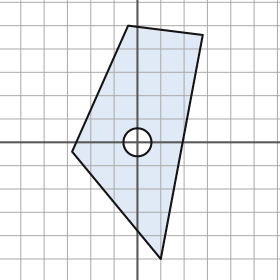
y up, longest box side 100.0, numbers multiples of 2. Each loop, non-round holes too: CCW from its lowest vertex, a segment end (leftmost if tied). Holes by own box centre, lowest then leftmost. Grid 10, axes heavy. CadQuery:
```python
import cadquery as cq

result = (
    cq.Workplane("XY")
    .moveTo(10.0, -50.0)
    .lineTo(28.0, 46.0)
    .lineTo(-4.0, 50.0)
    .lineTo(-28.0, -4.0)
    .close()
    .moveTo(0.0, 0.0)
    .circle(6.0)
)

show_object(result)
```